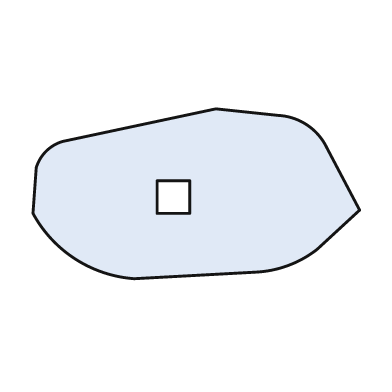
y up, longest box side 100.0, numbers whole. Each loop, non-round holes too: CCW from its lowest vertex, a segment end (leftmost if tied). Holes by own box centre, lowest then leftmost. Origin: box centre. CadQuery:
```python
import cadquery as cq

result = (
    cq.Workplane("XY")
    .moveTo(-19.0, -26.0)
    .lineTo(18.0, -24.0)
    .threePointArc((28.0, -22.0), (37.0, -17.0))
    .lineTo(50.0, -5.0)
    .lineTo(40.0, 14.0)
    .threePointArc((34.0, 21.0), (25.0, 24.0))
    .lineTo(6.0, 26.0)
    .lineTo(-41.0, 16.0)
    .threePointArc((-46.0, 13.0), (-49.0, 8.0))
    .lineTo(-50.0, -6.0)
    .threePointArc((-37.0, -20.0), (-19.0, -26.0))
    .close()
    .moveTo(-12.0, -6.0)
    .lineTo(-2.0, -6.0)
    .lineTo(-2.0, 4.0)
    .lineTo(-12.0, 4.0)
    .close()
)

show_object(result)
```